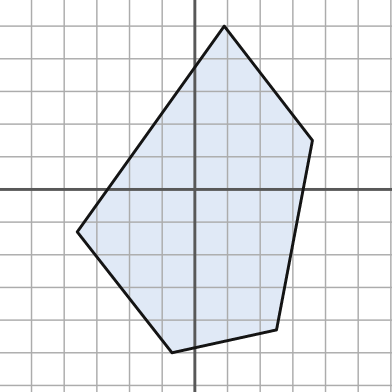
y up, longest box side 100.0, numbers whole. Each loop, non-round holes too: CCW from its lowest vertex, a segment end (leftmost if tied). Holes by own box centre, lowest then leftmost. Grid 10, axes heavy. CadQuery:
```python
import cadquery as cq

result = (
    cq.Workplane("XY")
    .moveTo(-7.0, -50.0)
    .lineTo(25.0, -43.0)
    .lineTo(36.0, 15.0)
    .lineTo(9.0, 50.0)
    .lineTo(-36.0, -13.0)
    .close()
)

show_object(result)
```